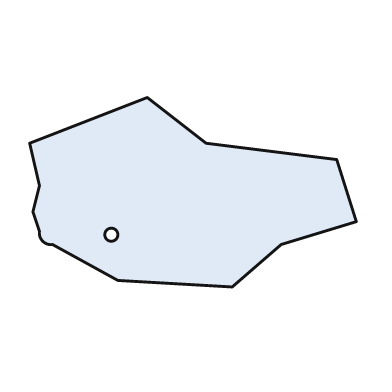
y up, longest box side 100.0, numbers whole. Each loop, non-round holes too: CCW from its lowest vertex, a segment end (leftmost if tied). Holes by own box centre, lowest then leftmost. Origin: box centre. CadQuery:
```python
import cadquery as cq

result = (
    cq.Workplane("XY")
    .moveTo(12.0, -29.0)
    .lineTo(27.0, -16.0)
    .lineTo(50.0, -9.0)
    .lineTo(44.0, 10.0)
    .lineTo(4.0, 15.0)
    .lineTo(-14.0, 29.0)
    .lineTo(-50.0, 15.0)
    .lineTo(-47.0, 2.0)
    .lineTo(-49.0, -6.0)
    .lineTo(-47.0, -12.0)
    .threePointArc((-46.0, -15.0), (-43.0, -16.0))
    .lineTo(-23.0, -27.0)
    .close()
    .moveTo(-25.0, -13.0)
    .circle(2.0)
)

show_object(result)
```